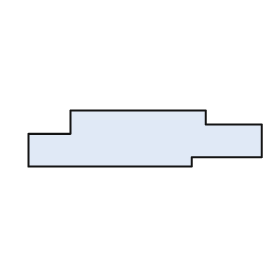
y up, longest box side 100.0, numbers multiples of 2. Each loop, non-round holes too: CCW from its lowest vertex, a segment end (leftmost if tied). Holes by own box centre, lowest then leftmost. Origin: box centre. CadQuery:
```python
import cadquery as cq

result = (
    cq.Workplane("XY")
    .moveTo(-50.0, -12.0)
    .lineTo(20.0, -12.0)
    .lineTo(20.0, -8.0)
    .lineTo(50.0, -8.0)
    .lineTo(50.0, 6.0)
    .lineTo(26.0, 6.0)
    .lineTo(26.0, 12.0)
    .lineTo(-32.0, 12.0)
    .lineTo(-32.0, 2.0)
    .lineTo(-50.0, 2.0)
    .close()
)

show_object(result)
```